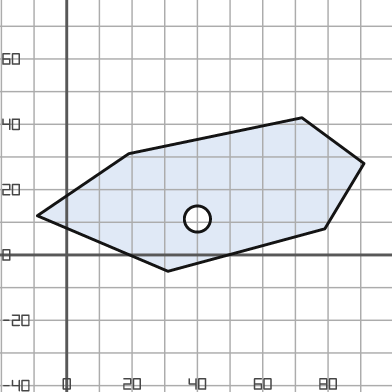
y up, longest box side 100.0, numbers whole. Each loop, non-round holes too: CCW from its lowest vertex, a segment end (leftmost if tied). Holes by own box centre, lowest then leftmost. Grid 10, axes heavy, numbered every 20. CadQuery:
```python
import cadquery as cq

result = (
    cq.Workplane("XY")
    .moveTo(31.0, -5.0)
    .lineTo(79.0, 8.0)
    .lineTo(91.0, 28.0)
    .lineTo(72.0, 42.0)
    .lineTo(19.0, 31.0)
    .lineTo(-9.0, 12.0)
    .close()
    .moveTo(40.0, 11.0)
    .circle(4.0)
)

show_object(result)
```